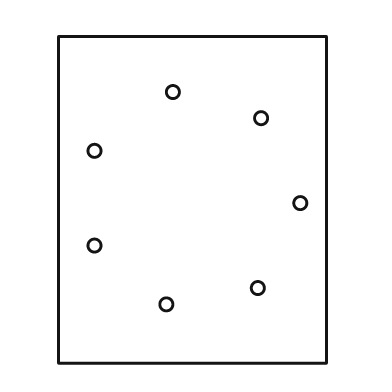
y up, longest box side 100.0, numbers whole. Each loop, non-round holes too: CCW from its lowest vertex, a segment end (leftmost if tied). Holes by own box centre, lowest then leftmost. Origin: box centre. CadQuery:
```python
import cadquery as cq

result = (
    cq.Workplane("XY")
    .moveTo(-41.0, -50.0)
    .lineTo(41.0, -50.0)
    .lineTo(41.0, 50.0)
    .lineTo(-41.0, 50.0)
    .close()
    .moveTo(-8.0, -32.0)
    .circle(2.0)
    .moveTo(20.0, -27.0)
    .circle(2.0)
    .moveTo(-30.0, -14.0)
    .circle(2.0)
    .moveTo(33.0, -1.0)
    .circle(2.0)
    .moveTo(-30.0, 15.0)
    .circle(2.0)
    .moveTo(21.0, 25.0)
    .circle(2.0)
    .moveTo(-6.0, 33.0)
    .circle(2.0)
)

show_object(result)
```